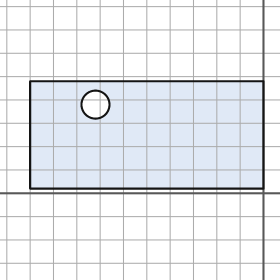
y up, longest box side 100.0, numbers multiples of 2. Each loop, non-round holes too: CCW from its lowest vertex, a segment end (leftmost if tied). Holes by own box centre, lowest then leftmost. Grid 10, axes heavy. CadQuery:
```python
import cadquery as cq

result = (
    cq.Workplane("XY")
    .moveTo(-100.0, 2.0)
    .lineTo(0.0, 2.0)
    .lineTo(0.0, 48.0)
    .lineTo(-100.0, 48.0)
    .close()
    .moveTo(-72.0, 38.0)
    .circle(6.0)
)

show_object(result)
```